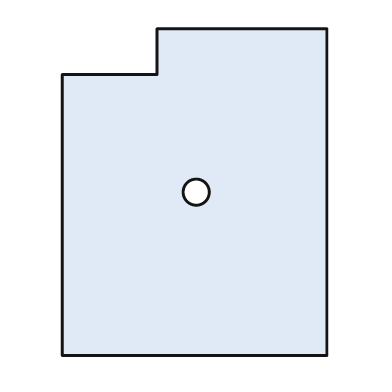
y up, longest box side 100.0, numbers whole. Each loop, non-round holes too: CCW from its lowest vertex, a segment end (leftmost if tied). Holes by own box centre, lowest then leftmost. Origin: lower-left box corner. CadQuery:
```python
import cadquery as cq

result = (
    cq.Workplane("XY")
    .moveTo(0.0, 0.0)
    .lineTo(81.0, 0.0)
    .lineTo(81.0, 100.0)
    .lineTo(29.0, 100.0)
    .lineTo(29.0, 86.0)
    .lineTo(0.0, 86.0)
    .close()
    .moveTo(41.0, 50.0)
    .circle(4.0)
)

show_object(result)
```